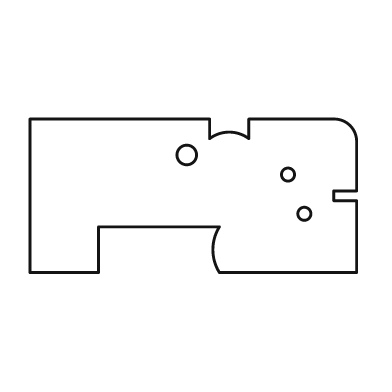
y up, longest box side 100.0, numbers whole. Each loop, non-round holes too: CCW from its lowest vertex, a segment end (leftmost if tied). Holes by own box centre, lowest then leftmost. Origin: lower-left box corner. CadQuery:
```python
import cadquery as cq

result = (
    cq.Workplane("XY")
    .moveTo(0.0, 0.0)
    .lineTo(21.0, 0.0)
    .lineTo(21.0, 14.0)
    .lineTo(58.0, 14.0)
    .threePointArc((56.0, 7.0), (58.0, 0.0))
    .lineTo(100.0, 0.0)
    .lineTo(100.0, 22.0)
    .lineTo(93.0, 22.0)
    .lineTo(93.0, 25.0)
    .lineTo(100.0, 25.0)
    .lineTo(100.0, 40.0)
    .threePointArc((98.0, 45.0), (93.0, 47.0))
    .lineTo(67.0, 47.0)
    .lineTo(67.0, 41.0)
    .threePointArc((61.0, 43.0), (55.0, 41.0))
    .lineTo(55.0, 47.0)
    .lineTo(0.0, 47.0)
    .close()
    .moveTo(84.0, 18.0)
    .circle(2.0)
    .moveTo(79.0, 30.0)
    .circle(2.0)
    .moveTo(48.0, 36.0)
    .circle(3.0)
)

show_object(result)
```